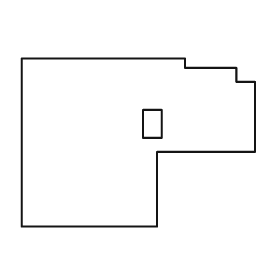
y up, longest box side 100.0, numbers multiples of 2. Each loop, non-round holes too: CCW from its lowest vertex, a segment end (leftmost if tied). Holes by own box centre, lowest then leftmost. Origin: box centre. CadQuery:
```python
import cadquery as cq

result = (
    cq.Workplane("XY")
    .moveTo(-50.0, -36.0)
    .lineTo(8.0, -36.0)
    .lineTo(8.0, -4.0)
    .lineTo(50.0, -4.0)
    .lineTo(50.0, 26.0)
    .lineTo(42.0, 26.0)
    .lineTo(42.0, 32.0)
    .lineTo(20.0, 32.0)
    .lineTo(20.0, 36.0)
    .lineTo(-50.0, 36.0)
    .close()
    .moveTo(2.0, 2.0)
    .lineTo(10.0, 2.0)
    .lineTo(10.0, 14.0)
    .lineTo(2.0, 14.0)
    .close()
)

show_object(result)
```